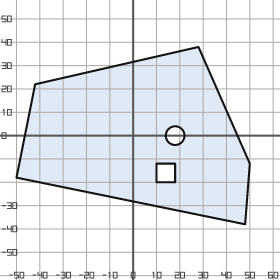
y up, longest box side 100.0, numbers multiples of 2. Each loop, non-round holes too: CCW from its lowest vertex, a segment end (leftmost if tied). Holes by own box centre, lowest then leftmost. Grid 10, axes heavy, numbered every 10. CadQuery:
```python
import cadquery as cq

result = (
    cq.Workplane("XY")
    .moveTo(48.0, -38.0)
    .lineTo(50.0, -12.0)
    .lineTo(28.0, 38.0)
    .lineTo(-42.0, 22.0)
    .lineTo(-50.0, -18.0)
    .close()
    .moveTo(10.0, -20.0)
    .lineTo(18.0, -20.0)
    .lineTo(18.0, -12.0)
    .lineTo(10.0, -12.0)
    .close()
    .moveTo(18.0, 0.0)
    .circle(4.0)
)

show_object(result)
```